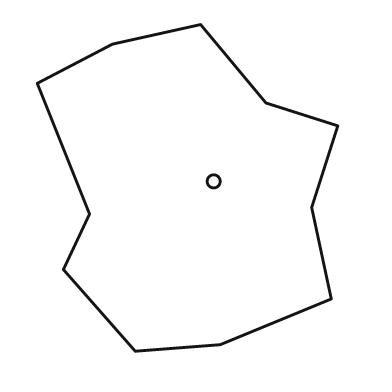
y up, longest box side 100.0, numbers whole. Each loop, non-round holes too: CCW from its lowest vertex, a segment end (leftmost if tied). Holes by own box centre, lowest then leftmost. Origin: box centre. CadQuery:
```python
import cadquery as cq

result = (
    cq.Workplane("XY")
    .moveTo(-16.0, -50.0)
    .lineTo(10.0, -48.0)
    .lineTo(44.0, -34.0)
    .lineTo(38.0, -6.0)
    .lineTo(46.0, 19.0)
    .lineTo(24.0, 26.0)
    .lineTo(4.0, 50.0)
    .lineTo(-23.0, 44.0)
    .lineTo(-46.0, 32.0)
    .lineTo(-30.0, -8.0)
    .lineTo(-38.0, -25.0)
    .close()
    .moveTo(8.0, 2.0)
    .circle(2.0)
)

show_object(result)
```